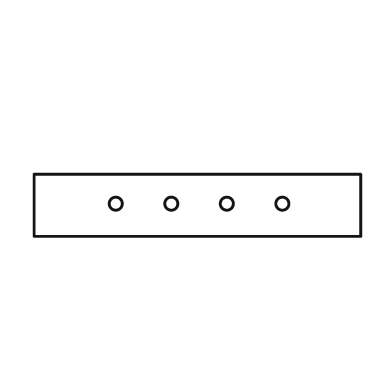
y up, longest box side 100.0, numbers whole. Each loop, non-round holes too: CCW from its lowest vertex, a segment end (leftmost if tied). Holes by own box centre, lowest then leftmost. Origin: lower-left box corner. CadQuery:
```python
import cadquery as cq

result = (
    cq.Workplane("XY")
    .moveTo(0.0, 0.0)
    .lineTo(100.0, 0.0)
    .lineTo(100.0, 19.0)
    .lineTo(0.0, 19.0)
    .close()
    .moveTo(25.0, 10.0)
    .circle(2.0)
    .moveTo(42.0, 10.0)
    .circle(2.0)
    .moveTo(59.0, 10.0)
    .circle(2.0)
    .moveTo(76.0, 10.0)
    .circle(2.0)
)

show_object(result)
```